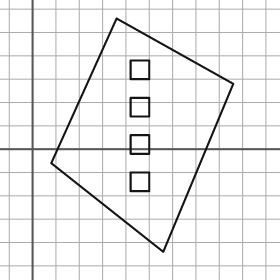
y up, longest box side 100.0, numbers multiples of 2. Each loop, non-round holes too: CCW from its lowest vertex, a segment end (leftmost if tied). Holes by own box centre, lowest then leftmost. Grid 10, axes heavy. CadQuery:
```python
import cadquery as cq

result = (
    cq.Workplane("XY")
    .moveTo(56.0, -44.0)
    .lineTo(86.0, 28.0)
    .lineTo(36.0, 56.0)
    .lineTo(8.0, -6.0)
    .close()
    .moveTo(42.0, -18.0)
    .lineTo(50.0, -18.0)
    .lineTo(50.0, -10.0)
    .lineTo(42.0, -10.0)
    .close()
    .moveTo(42.0, -2.0)
    .lineTo(50.0, -2.0)
    .lineTo(50.0, 6.0)
    .lineTo(42.0, 6.0)
    .close()
    .moveTo(42.0, 14.0)
    .lineTo(50.0, 14.0)
    .lineTo(50.0, 22.0)
    .lineTo(42.0, 22.0)
    .close()
    .moveTo(42.0, 30.0)
    .lineTo(50.0, 30.0)
    .lineTo(50.0, 38.0)
    .lineTo(42.0, 38.0)
    .close()
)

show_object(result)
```